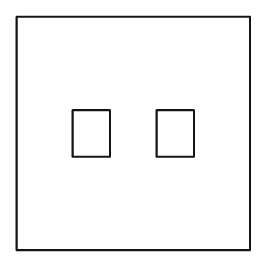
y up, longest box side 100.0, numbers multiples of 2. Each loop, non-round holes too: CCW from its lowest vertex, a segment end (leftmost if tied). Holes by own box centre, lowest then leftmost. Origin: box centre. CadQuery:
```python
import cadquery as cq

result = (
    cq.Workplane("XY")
    .moveTo(-50.0, -50.0)
    .lineTo(50.0, -50.0)
    .lineTo(50.0, 50.0)
    .lineTo(-50.0, 50.0)
    .close()
    .moveTo(-26.0, -10.0)
    .lineTo(-10.0, -10.0)
    .lineTo(-10.0, 10.0)
    .lineTo(-26.0, 10.0)
    .close()
    .moveTo(10.0, -10.0)
    .lineTo(26.0, -10.0)
    .lineTo(26.0, 10.0)
    .lineTo(10.0, 10.0)
    .close()
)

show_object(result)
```